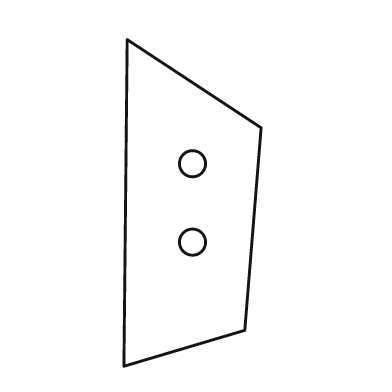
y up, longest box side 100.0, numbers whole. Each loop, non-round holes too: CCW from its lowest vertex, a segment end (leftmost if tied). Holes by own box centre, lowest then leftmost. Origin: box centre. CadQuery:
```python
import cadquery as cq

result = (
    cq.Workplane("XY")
    .moveTo(-21.0, -50.0)
    .lineTo(16.0, -39.0)
    .lineTo(21.0, 23.0)
    .lineTo(-20.0, 50.0)
    .close()
    .moveTo(0.0, -12.0)
    .circle(4.0)
    .moveTo(0.0, 12.0)
    .circle(4.0)
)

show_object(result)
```